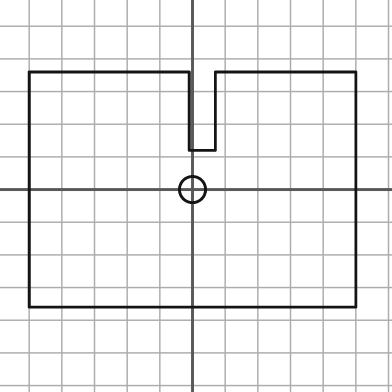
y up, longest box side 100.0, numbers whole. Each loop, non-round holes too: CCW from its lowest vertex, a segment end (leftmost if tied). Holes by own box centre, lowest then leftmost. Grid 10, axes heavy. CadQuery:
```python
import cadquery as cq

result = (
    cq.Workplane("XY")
    .moveTo(-50.0, -36.0)
    .lineTo(50.0, -36.0)
    .lineTo(50.0, 36.0)
    .lineTo(7.0, 36.0)
    .lineTo(7.0, 12.0)
    .lineTo(-1.0, 12.0)
    .lineTo(-1.0, 36.0)
    .lineTo(-50.0, 36.0)
    .close()
    .moveTo(0.0, 0.0)
    .circle(4.0)
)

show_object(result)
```